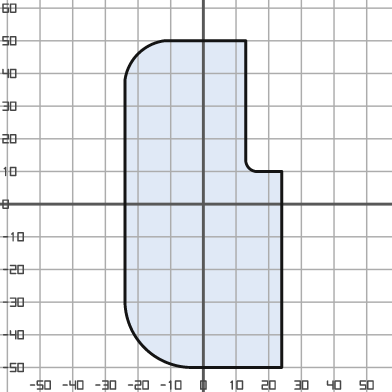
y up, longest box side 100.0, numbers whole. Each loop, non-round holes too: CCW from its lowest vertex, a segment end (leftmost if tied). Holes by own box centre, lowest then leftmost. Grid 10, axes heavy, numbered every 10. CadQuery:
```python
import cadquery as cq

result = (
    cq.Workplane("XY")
    .moveTo(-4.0, -50.0)
    .lineTo(24.0, -50.0)
    .lineTo(24.0, 10.0)
    .lineTo(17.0, 10.0)
    .threePointArc((14.0, 11.0), (13.0, 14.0))
    .lineTo(13.0, 50.0)
    .lineTo(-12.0, 50.0)
    .threePointArc((-20.0, 46.0), (-24.0, 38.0))
    .lineTo(-24.0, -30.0)
    .threePointArc((-18.0, -44.0), (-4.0, -50.0))
    .close()
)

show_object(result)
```